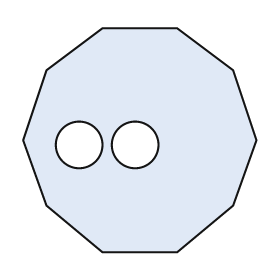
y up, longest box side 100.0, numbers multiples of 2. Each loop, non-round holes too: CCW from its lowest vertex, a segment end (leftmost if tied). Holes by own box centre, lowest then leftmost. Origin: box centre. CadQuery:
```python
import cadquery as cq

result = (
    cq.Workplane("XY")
    .moveTo(-16.0, -48.0)
    .lineTo(16.0, -48.0)
    .lineTo(40.0, -28.0)
    .lineTo(50.0, 0.0)
    .lineTo(40.0, 30.0)
    .lineTo(16.0, 48.0)
    .lineTo(-16.0, 48.0)
    .lineTo(-40.0, 30.0)
    .lineTo(-50.0, 0.0)
    .lineTo(-40.0, -28.0)
    .close()
    .moveTo(-26.0, -2.0)
    .circle(10.0)
    .moveTo(-2.0, -2.0)
    .circle(10.0)
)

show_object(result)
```